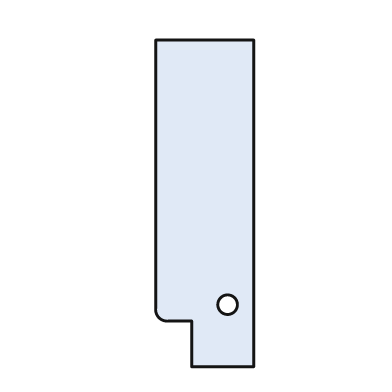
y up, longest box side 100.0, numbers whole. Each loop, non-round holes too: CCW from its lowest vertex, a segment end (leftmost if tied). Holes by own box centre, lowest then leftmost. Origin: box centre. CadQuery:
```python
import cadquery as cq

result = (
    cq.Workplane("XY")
    .moveTo(-4.0, -50.0)
    .lineTo(15.0, -50.0)
    .lineTo(15.0, 50.0)
    .lineTo(-15.0, 50.0)
    .lineTo(-15.0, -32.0)
    .threePointArc((-14.0, -35.0), (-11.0, -36.0))
    .lineTo(-4.0, -36.0)
    .close()
    .moveTo(7.0, -31.0)
    .circle(3.0)
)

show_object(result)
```